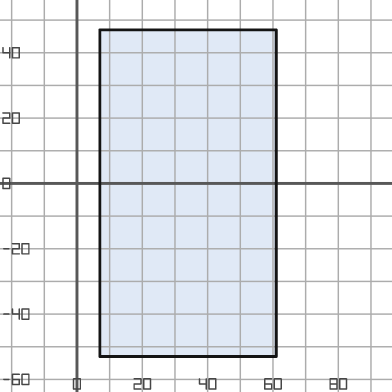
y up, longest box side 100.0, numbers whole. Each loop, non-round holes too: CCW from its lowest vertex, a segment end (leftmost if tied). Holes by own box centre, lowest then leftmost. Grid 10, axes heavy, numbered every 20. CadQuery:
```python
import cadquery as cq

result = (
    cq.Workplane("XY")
    .moveTo(7.0, -53.0)
    .lineTo(61.0, -53.0)
    .lineTo(61.0, 47.0)
    .lineTo(7.0, 47.0)
    .close()
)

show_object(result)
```